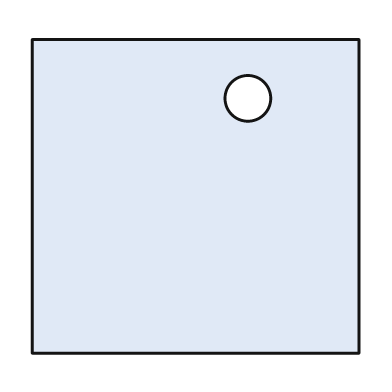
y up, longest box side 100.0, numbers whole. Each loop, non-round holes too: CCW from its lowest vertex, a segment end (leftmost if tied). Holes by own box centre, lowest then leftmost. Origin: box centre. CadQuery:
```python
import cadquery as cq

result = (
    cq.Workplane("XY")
    .moveTo(-50.0, -48.0)
    .lineTo(50.0, -48.0)
    .lineTo(50.0, 48.0)
    .lineTo(-50.0, 48.0)
    .close()
    .moveTo(16.0, 30.0)
    .circle(7.0)
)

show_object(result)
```